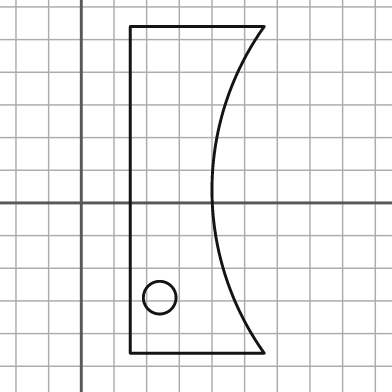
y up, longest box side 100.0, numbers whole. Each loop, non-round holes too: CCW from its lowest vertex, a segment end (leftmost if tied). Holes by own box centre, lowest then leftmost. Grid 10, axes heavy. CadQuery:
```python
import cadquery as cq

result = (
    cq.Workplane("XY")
    .moveTo(15.0, -46.0)
    .lineTo(56.0, -46.0)
    .threePointArc((40.0, 4.0), (56.0, 54.0))
    .lineTo(15.0, 54.0)
    .close()
    .moveTo(24.0, -29.0)
    .circle(5.0)
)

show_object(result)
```